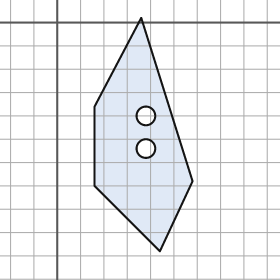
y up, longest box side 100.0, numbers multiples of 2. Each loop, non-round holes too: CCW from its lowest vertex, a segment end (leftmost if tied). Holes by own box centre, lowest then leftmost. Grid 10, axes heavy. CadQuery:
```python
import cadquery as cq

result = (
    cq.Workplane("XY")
    .moveTo(44.0, -98.0)
    .lineTo(58.0, -68.0)
    .lineTo(36.0, 2.0)
    .lineTo(16.0, -36.0)
    .lineTo(16.0, -70.0)
    .close()
    .moveTo(38.0, -54.0)
    .circle(4.0)
    .moveTo(38.0, -40.0)
    .circle(4.0)
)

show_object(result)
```